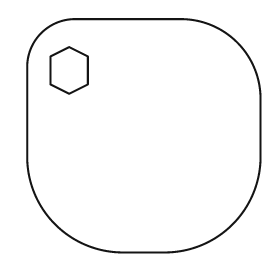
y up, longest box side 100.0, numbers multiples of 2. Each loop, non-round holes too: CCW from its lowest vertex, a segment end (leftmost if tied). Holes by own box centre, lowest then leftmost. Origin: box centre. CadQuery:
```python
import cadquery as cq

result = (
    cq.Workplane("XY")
    .moveTo(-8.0, -50.0)
    .lineTo(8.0, -50.0)
    .threePointArc((38.0, -38.0), (50.0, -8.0))
    .lineTo(50.0, 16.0)
    .threePointArc((40.0, 40.0), (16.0, 50.0))
    .lineTo(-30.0, 50.0)
    .threePointArc((-44.0, 44.0), (-50.0, 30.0))
    .lineTo(-50.0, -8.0)
    .threePointArc((-38.0, -38.0), (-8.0, -50.0))
    .close()
    .moveTo(-32.0, 18.0)
    .lineTo(-24.0, 22.0)
    .lineTo(-24.0, 34.0)
    .lineTo(-32.0, 38.0)
    .lineTo(-40.0, 34.0)
    .lineTo(-40.0, 22.0)
    .close()
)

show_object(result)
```